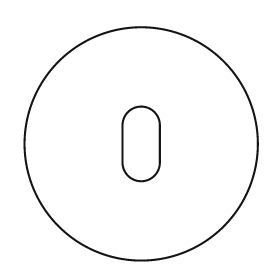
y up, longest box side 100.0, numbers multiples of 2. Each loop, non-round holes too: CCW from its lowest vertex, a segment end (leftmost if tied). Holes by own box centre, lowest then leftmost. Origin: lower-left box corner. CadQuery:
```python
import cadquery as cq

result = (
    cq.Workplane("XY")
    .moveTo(50.0, 50.0)
    .circle(50.0)
    .moveTo(42.0, 42.0)
    .threePointArc((50.0, 34.0), (58.0, 42.0))
    .lineTo(58.0, 58.0)
    .threePointArc((50.0, 66.0), (42.0, 58.0))
    .close()
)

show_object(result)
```